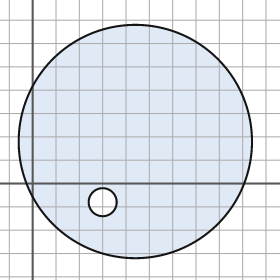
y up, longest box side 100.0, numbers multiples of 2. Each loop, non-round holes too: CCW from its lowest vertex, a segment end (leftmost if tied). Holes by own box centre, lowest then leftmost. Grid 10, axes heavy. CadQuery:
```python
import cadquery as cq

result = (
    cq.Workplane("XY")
    .moveTo(44.0, 18.0)
    .circle(50.0)
    .moveTo(30.0, -8.0)
    .circle(6.0)
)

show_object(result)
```